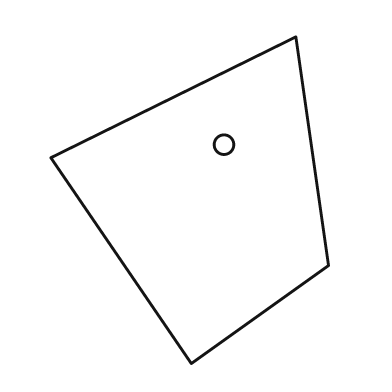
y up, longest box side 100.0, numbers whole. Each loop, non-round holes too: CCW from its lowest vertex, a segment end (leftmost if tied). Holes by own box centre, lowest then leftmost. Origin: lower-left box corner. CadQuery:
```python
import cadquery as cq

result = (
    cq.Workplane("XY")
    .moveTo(43.0, 0.0)
    .lineTo(85.0, 30.0)
    .lineTo(75.0, 100.0)
    .lineTo(0.0, 63.0)
    .close()
    .moveTo(53.0, 67.0)
    .circle(3.0)
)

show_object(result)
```